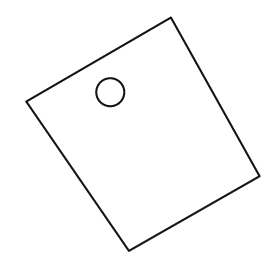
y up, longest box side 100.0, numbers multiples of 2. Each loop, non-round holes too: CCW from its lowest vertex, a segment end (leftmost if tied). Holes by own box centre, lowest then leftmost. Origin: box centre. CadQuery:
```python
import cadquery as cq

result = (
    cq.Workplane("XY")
    .moveTo(-6.0, -50.0)
    .lineTo(50.0, -18.0)
    .lineTo(12.0, 50.0)
    .lineTo(-50.0, 14.0)
    .close()
    .moveTo(-14.0, 18.0)
    .circle(6.0)
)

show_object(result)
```